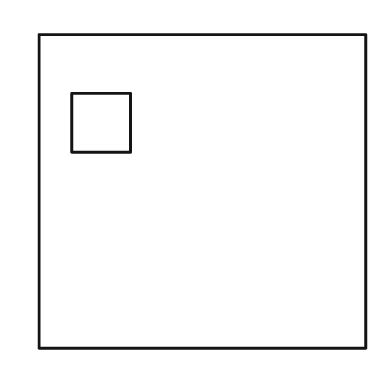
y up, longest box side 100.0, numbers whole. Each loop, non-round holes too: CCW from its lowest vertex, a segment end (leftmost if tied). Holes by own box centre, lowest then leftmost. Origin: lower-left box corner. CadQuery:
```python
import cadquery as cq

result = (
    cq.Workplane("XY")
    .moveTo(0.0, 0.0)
    .lineTo(100.0, 0.0)
    .lineTo(100.0, 96.0)
    .lineTo(0.0, 96.0)
    .close()
    .moveTo(10.0, 60.0)
    .lineTo(28.0, 60.0)
    .lineTo(28.0, 78.0)
    .lineTo(10.0, 78.0)
    .close()
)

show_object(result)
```